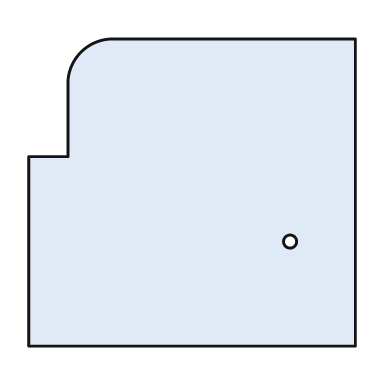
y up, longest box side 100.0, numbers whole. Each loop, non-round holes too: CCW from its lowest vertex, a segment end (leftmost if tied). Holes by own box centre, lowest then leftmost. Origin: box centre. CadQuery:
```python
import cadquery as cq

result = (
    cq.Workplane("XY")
    .moveTo(-50.0, -47.0)
    .lineTo(50.0, -47.0)
    .lineTo(50.0, 47.0)
    .lineTo(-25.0, 47.0)
    .threePointArc((-34.0, 43.0), (-38.0, 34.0))
    .lineTo(-38.0, 11.0)
    .lineTo(-50.0, 11.0)
    .close()
    .moveTo(30.0, -15.0)
    .circle(2.0)
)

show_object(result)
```